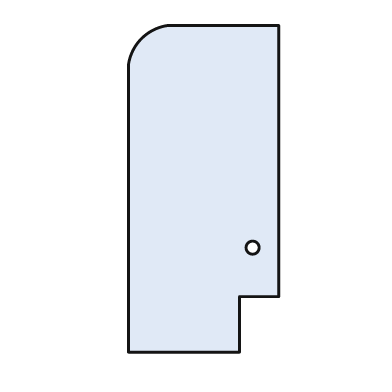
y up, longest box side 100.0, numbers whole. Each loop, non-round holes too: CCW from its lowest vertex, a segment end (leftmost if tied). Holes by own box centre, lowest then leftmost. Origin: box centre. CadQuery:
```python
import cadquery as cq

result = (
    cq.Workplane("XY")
    .moveTo(-23.0, -50.0)
    .lineTo(11.0, -50.0)
    .lineTo(11.0, -33.0)
    .lineTo(23.0, -33.0)
    .lineTo(23.0, 50.0)
    .lineTo(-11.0, 50.0)
    .threePointArc((-19.0, 46.0), (-23.0, 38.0))
    .close()
    .moveTo(15.0, -18.0)
    .circle(2.0)
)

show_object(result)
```